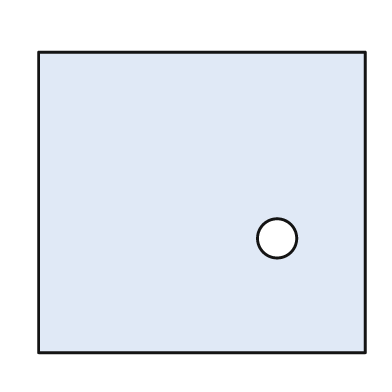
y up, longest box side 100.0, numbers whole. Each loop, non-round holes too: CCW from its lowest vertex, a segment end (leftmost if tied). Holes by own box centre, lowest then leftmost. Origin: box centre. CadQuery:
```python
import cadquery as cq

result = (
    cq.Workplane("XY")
    .moveTo(-50.0, -46.0)
    .lineTo(50.0, -46.0)
    .lineTo(50.0, 46.0)
    .lineTo(-50.0, 46.0)
    .close()
    .moveTo(23.0, -11.0)
    .circle(6.0)
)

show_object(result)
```